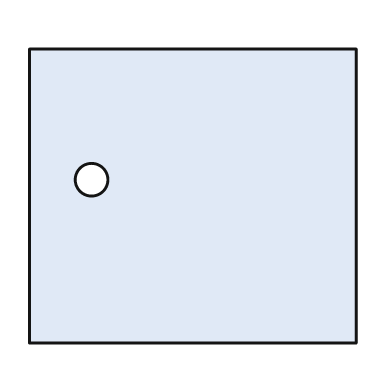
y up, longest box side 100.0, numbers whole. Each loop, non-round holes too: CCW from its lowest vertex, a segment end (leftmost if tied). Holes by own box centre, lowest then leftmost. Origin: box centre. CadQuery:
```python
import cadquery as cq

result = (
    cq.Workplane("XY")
    .moveTo(-50.0, -45.0)
    .lineTo(50.0, -45.0)
    .lineTo(50.0, 45.0)
    .lineTo(-50.0, 45.0)
    .close()
    .moveTo(-31.0, 5.0)
    .circle(5.0)
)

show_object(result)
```